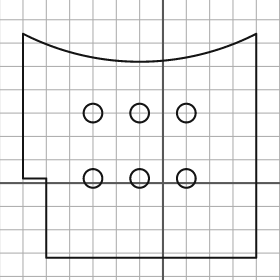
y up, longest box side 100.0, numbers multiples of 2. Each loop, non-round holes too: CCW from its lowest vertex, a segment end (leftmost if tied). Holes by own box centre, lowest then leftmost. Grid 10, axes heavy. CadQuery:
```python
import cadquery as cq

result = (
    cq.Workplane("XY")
    .moveTo(-50.0, -32.0)
    .lineTo(40.0, -32.0)
    .lineTo(40.0, 64.0)
    .threePointArc((-10.0, 52.0), (-60.0, 64.0))
    .lineTo(-60.0, 2.0)
    .lineTo(-50.0, 2.0)
    .close()
    .moveTo(-30.0, 2.0)
    .circle(4.0)
    .moveTo(-10.0, 2.0)
    .circle(4.0)
    .moveTo(10.0, 2.0)
    .circle(4.0)
    .moveTo(-30.0, 30.0)
    .circle(4.0)
    .moveTo(-10.0, 30.0)
    .circle(4.0)
    .moveTo(10.0, 30.0)
    .circle(4.0)
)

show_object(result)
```